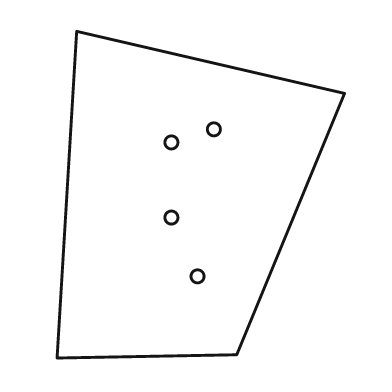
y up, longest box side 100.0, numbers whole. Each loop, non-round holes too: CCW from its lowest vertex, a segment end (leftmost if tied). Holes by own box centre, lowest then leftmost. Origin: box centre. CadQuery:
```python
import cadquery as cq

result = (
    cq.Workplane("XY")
    .moveTo(-44.0, -50.0)
    .lineTo(11.0, -49.0)
    .lineTo(44.0, 31.0)
    .lineTo(-38.0, 50.0)
    .close()
    .moveTo(-1.0, -25.0)
    .circle(2.0)
    .moveTo(-9.0, -7.0)
    .circle(2.0)
    .moveTo(-9.0, 16.0)
    .circle(2.0)
    .moveTo(4.0, 20.0)
    .circle(2.0)
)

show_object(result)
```